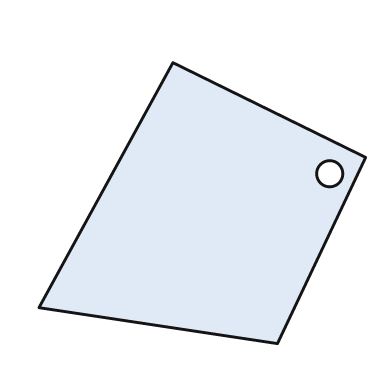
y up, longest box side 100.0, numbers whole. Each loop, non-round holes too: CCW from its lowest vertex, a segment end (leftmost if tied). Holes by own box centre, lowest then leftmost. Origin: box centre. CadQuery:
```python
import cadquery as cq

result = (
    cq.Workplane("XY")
    .moveTo(23.0, -43.0)
    .lineTo(50.0, 14.0)
    .lineTo(-9.0, 43.0)
    .lineTo(-50.0, -32.0)
    .close()
    .moveTo(39.0, 9.0)
    .circle(4.0)
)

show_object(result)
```